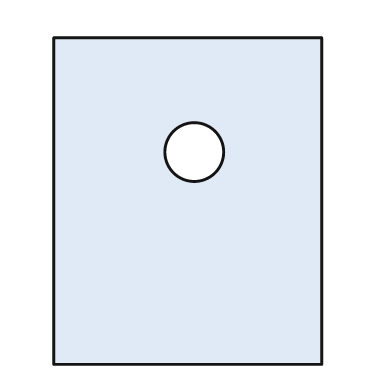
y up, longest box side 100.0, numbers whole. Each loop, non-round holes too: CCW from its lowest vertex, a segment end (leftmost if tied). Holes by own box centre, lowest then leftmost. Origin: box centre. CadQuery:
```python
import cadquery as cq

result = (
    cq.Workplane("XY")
    .moveTo(-41.0, -50.0)
    .lineTo(41.0, -50.0)
    .lineTo(41.0, 50.0)
    .lineTo(-41.0, 50.0)
    .close()
    .moveTo(2.0, 15.0)
    .circle(9.0)
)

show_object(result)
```